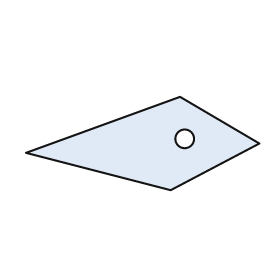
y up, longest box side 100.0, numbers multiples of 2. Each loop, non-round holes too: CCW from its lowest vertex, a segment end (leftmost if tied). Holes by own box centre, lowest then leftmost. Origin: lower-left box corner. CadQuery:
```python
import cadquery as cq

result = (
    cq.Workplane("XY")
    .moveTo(62.0, 0.0)
    .lineTo(100.0, 20.0)
    .lineTo(66.0, 40.0)
    .lineTo(0.0, 16.0)
    .close()
    .moveTo(68.0, 22.0)
    .circle(4.0)
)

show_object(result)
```